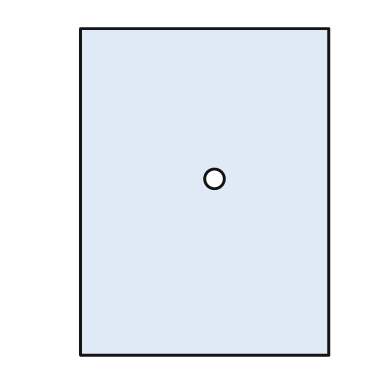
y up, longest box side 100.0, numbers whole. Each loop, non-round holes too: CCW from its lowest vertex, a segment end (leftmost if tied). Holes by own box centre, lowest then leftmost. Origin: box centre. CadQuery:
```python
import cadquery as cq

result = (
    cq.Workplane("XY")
    .moveTo(-38.0, -50.0)
    .lineTo(38.0, -50.0)
    .lineTo(38.0, 50.0)
    .lineTo(-38.0, 50.0)
    .close()
    .moveTo(3.0, 4.0)
    .circle(3.0)
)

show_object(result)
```